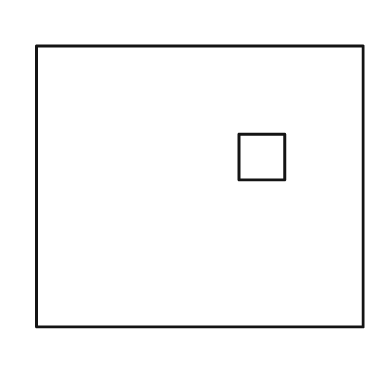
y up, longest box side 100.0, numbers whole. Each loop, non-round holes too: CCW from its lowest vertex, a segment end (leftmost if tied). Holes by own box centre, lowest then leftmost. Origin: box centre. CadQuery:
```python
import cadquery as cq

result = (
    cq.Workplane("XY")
    .moveTo(-50.0, -43.0)
    .lineTo(50.0, -43.0)
    .lineTo(50.0, 43.0)
    .lineTo(-50.0, 43.0)
    .close()
    .moveTo(12.0, 2.0)
    .lineTo(26.0, 2.0)
    .lineTo(26.0, 16.0)
    .lineTo(12.0, 16.0)
    .close()
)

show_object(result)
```